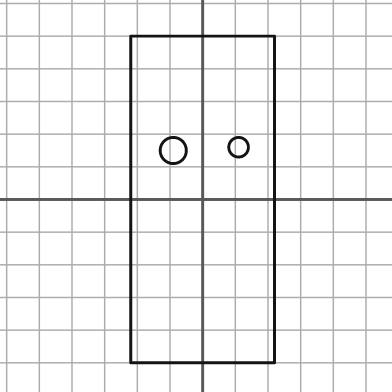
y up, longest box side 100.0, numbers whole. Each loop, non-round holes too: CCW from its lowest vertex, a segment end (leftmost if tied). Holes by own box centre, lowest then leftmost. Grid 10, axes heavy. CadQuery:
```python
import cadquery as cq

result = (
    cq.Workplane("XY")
    .moveTo(-22.0, -50.0)
    .lineTo(22.0, -50.0)
    .lineTo(22.0, 50.0)
    .lineTo(-22.0, 50.0)
    .close()
    .moveTo(-9.0, 15.0)
    .circle(4.0)
    .moveTo(11.0, 16.0)
    .circle(3.0)
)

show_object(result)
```